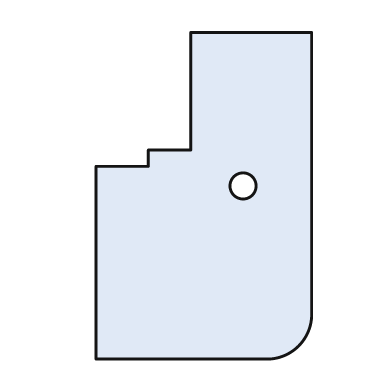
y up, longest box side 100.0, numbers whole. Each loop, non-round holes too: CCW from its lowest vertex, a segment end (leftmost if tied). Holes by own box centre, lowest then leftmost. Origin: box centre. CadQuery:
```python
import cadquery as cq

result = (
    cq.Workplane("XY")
    .moveTo(-33.0, -50.0)
    .lineTo(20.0, -50.0)
    .threePointArc((29.0, -46.0), (33.0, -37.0))
    .lineTo(33.0, 50.0)
    .lineTo(-4.0, 50.0)
    .lineTo(-4.0, 14.0)
    .lineTo(-17.0, 14.0)
    .lineTo(-17.0, 9.0)
    .lineTo(-33.0, 9.0)
    .close()
    .moveTo(12.0, 3.0)
    .circle(4.0)
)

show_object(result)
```